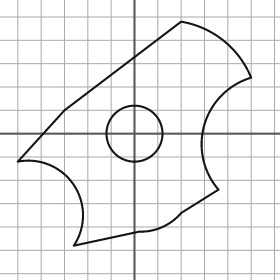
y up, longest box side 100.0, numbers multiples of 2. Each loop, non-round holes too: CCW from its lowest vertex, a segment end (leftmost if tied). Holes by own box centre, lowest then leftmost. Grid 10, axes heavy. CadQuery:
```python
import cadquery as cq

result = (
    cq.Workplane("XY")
    .moveTo(-26.0, -48.0)
    .lineTo(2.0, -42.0)
    .threePointArc((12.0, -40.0), (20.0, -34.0))
    .lineTo(36.0, -24.0)
    .threePointArc((30.0, 4.0), (50.0, 24.0))
    .threePointArc((38.0, 40.0), (20.0, 48.0))
    .lineTo(-30.0, 10.0)
    .lineTo(-50.0, -12.0)
    .threePointArc((-26.0, -22.0), (-26.0, -48.0))
    .close()
    .moveTo(0.0, 0.0)
    .circle(12.0)
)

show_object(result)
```